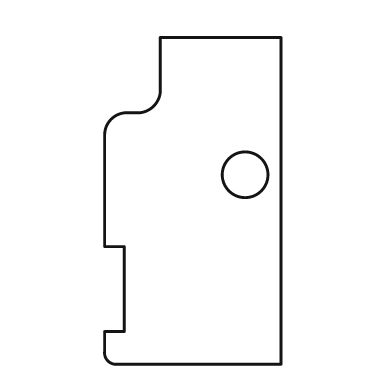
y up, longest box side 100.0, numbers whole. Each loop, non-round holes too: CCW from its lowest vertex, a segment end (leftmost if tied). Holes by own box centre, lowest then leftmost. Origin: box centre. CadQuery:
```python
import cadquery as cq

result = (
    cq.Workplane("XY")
    .moveTo(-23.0, -50.0)
    .lineTo(27.0, -50.0)
    .lineTo(27.0, 50.0)
    .lineTo(-10.0, 50.0)
    .lineTo(-10.0, 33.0)
    .threePointArc((-12.0, 29.0), (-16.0, 27.0))
    .lineTo(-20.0, 27.0)
    .threePointArc((-25.0, 25.0), (-27.0, 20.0))
    .lineTo(-27.0, -14.0)
    .lineTo(-21.0, -14.0)
    .lineTo(-21.0, -40.0)
    .lineTo(-27.0, -40.0)
    .lineTo(-27.0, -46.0)
    .threePointArc((-26.0, -49.0), (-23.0, -50.0))
    .close()
    .moveTo(16.0, 8.0)
    .circle(7.0)
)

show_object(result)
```